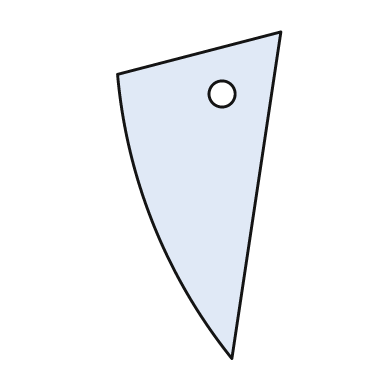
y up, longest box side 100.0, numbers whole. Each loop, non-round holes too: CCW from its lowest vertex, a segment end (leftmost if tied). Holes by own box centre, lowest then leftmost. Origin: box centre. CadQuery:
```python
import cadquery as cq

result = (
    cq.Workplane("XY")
    .moveTo(10.0, -50.0)
    .lineTo(25.0, 50.0)
    .lineTo(-25.0, 37.0)
    .threePointArc((-14.0, -9.0), (10.0, -50.0))
    .close()
    .moveTo(7.0, 31.0)
    .circle(4.0)
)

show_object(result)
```